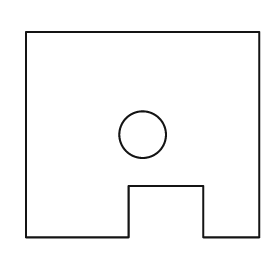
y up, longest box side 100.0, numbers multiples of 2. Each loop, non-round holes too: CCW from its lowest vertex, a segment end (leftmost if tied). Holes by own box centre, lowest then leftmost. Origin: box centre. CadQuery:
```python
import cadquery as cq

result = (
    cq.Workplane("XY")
    .moveTo(-50.0, -44.0)
    .lineTo(-6.0, -44.0)
    .lineTo(-6.0, -22.0)
    .lineTo(26.0, -22.0)
    .lineTo(26.0, -44.0)
    .lineTo(50.0, -44.0)
    .lineTo(50.0, 44.0)
    .lineTo(-50.0, 44.0)
    .close()
    .moveTo(0.0, 0.0)
    .circle(10.0)
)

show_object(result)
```